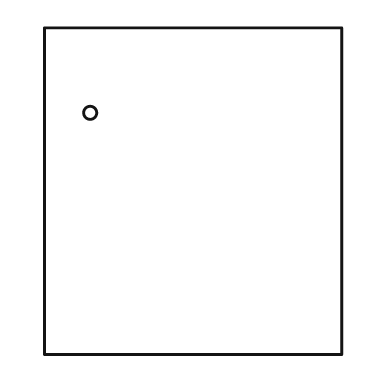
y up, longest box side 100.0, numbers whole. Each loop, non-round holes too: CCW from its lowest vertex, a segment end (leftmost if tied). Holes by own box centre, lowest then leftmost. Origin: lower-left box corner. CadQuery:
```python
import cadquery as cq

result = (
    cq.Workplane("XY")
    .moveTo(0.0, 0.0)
    .lineTo(91.0, 0.0)
    .lineTo(91.0, 100.0)
    .lineTo(0.0, 100.0)
    .close()
    .moveTo(14.0, 74.0)
    .circle(2.0)
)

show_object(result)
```